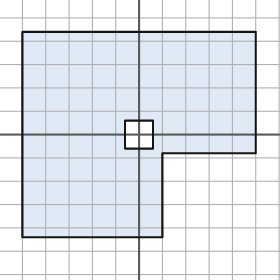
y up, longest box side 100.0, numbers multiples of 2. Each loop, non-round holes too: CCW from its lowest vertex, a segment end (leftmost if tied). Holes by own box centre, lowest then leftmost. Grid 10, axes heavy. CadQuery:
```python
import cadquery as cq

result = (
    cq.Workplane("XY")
    .moveTo(-50.0, -44.0)
    .lineTo(10.0, -44.0)
    .lineTo(10.0, -8.0)
    .lineTo(50.0, -8.0)
    .lineTo(50.0, 44.0)
    .lineTo(-50.0, 44.0)
    .close()
    .moveTo(-6.0, -6.0)
    .lineTo(6.0, -6.0)
    .lineTo(6.0, 6.0)
    .lineTo(-6.0, 6.0)
    .close()
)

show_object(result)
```